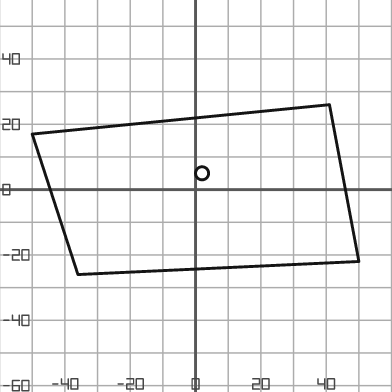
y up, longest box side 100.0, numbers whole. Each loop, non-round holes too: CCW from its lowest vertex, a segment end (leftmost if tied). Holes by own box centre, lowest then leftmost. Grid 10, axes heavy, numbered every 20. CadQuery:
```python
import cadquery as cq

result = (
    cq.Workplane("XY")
    .moveTo(-36.0, -26.0)
    .lineTo(50.0, -22.0)
    .lineTo(41.0, 26.0)
    .lineTo(-50.0, 17.0)
    .close()
    .moveTo(2.0, 5.0)
    .circle(2.0)
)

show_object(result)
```